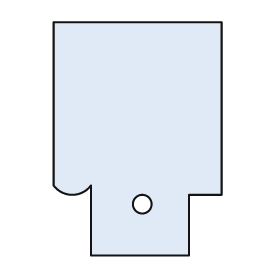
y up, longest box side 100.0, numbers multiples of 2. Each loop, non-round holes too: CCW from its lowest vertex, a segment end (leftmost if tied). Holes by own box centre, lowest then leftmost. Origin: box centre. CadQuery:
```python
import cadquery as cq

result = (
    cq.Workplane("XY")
    .moveTo(-20.0, -50.0)
    .lineTo(22.0, -50.0)
    .lineTo(22.0, -24.0)
    .lineTo(36.0, -24.0)
    .lineTo(36.0, 50.0)
    .lineTo(-36.0, 50.0)
    .lineTo(-36.0, -20.0)
    .threePointArc((-28.0, -24.0), (-20.0, -20.0))
    .close()
    .moveTo(2.0, -28.0)
    .circle(4.0)
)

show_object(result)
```